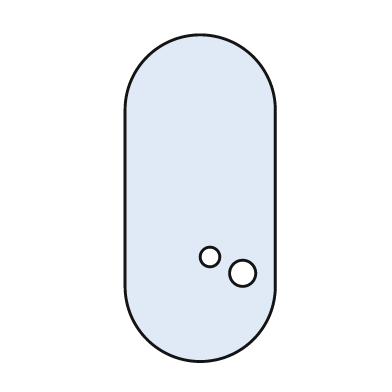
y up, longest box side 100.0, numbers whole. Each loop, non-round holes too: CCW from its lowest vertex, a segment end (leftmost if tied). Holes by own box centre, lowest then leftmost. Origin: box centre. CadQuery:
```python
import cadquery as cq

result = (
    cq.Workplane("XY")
    .moveTo(-23.0, -27.0)
    .threePointArc((0.0, -50.0), (23.0, -27.0))
    .lineTo(23.0, 27.0)
    .threePointArc((0.0, 50.0), (-23.0, 27.0))
    .close()
    .moveTo(13.0, -23.0)
    .circle(4.0)
    .moveTo(3.0, -18.0)
    .circle(3.0)
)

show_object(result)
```